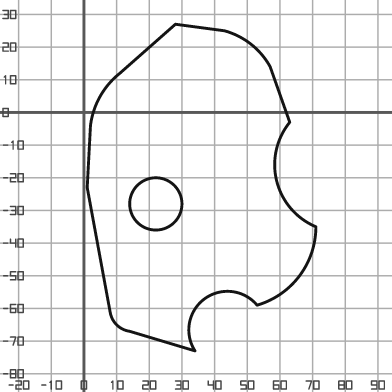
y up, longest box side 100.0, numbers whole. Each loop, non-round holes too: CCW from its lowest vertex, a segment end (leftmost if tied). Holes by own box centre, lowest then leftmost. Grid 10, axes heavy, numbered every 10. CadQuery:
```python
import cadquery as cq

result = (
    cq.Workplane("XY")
    .moveTo(34.0, -73.0)
    .threePointArc((37.0, -57.0), (53.0, -59.0))
    .threePointArc((66.0, -50.0), (71.0, -35.0))
    .threePointArc((59.0, -21.0), (63.0, -3.0))
    .lineTo(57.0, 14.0)
    .threePointArc((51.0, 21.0), (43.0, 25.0))
    .lineTo(28.0, 27.0)
    .lineTo(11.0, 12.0)
    .threePointArc((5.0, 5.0), (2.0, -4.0))
    .lineTo(1.0, -23.0)
    .lineTo(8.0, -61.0)
    .threePointArc((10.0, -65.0), (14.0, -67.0))
    .close()
    .moveTo(22.0, -28.0)
    .circle(8.0)
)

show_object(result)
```